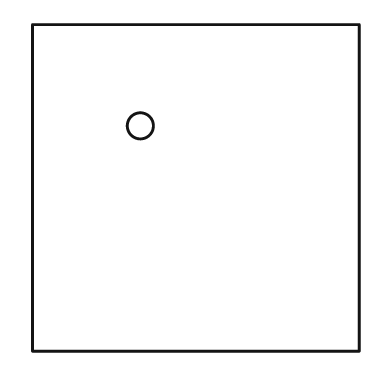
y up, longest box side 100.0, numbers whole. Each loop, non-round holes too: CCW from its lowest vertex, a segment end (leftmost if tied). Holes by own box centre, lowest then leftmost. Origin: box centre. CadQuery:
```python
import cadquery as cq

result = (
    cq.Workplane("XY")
    .moveTo(-50.0, -50.0)
    .lineTo(50.0, -50.0)
    .lineTo(50.0, 50.0)
    .lineTo(-50.0, 50.0)
    .close()
    .moveTo(-17.0, 19.0)
    .circle(4.0)
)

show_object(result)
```